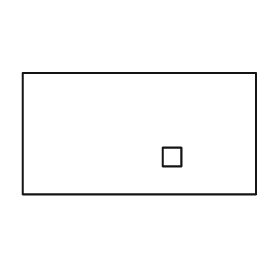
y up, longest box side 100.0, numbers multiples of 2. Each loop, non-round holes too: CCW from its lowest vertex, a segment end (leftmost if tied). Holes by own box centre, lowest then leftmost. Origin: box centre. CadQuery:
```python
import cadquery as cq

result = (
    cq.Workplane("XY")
    .moveTo(-50.0, -26.0)
    .lineTo(50.0, -26.0)
    .lineTo(50.0, 26.0)
    .lineTo(-50.0, 26.0)
    .close()
    .moveTo(10.0, -14.0)
    .lineTo(18.0, -14.0)
    .lineTo(18.0, -6.0)
    .lineTo(10.0, -6.0)
    .close()
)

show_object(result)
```